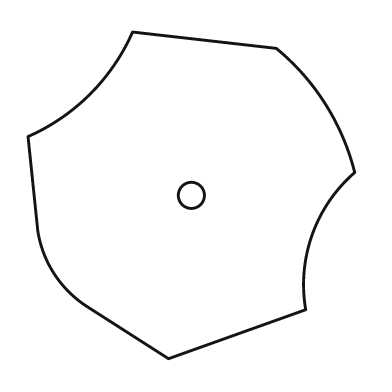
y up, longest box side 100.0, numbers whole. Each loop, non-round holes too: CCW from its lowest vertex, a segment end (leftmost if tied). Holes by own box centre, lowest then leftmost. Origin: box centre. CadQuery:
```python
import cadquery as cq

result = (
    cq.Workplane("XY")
    .moveTo(-7.0, -50.0)
    .lineTo(35.0, -35.0)
    .threePointArc((37.0, -12.0), (50.0, 7.0))
    .threePointArc((41.0, 28.0), (26.0, 45.0))
    .lineTo(-18.0, 50.0)
    .threePointArc((-31.0, 31.0), (-50.0, 18.0))
    .lineTo(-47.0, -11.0)
    .threePointArc((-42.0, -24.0), (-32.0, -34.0))
    .close()
    .moveTo(0.0, 0.0)
    .circle(4.0)
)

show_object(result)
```